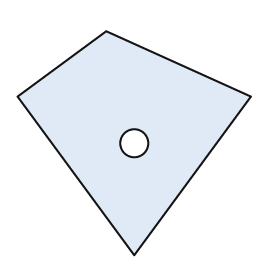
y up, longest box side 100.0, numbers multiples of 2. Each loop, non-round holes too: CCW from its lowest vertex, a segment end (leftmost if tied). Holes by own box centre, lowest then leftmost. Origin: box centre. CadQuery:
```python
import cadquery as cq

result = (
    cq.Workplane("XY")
    .moveTo(0.0, -48.0)
    .lineTo(50.0, 20.0)
    .lineTo(-12.0, 48.0)
    .lineTo(-50.0, 20.0)
    .close()
    .moveTo(0.0, 0.0)
    .circle(6.0)
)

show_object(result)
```